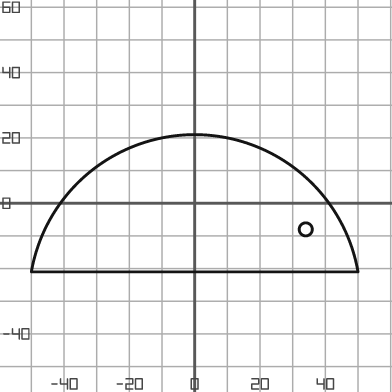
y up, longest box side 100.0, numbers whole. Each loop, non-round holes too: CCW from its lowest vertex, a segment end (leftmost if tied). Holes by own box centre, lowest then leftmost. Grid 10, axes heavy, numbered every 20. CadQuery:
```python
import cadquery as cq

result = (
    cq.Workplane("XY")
    .moveTo(-50.0, -21.0)
    .lineTo(50.0, -21.0)
    .threePointArc((0.0, 21.0), (-50.0, -21.0))
    .close()
    .moveTo(34.0, -8.0)
    .circle(2.0)
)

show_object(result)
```